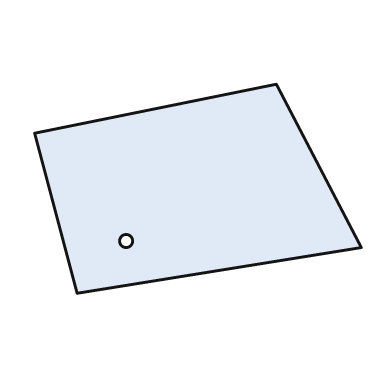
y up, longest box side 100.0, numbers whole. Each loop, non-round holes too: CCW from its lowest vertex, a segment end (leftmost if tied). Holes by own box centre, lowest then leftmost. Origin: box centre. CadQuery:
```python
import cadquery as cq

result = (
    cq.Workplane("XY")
    .moveTo(-37.0, -32.0)
    .lineTo(50.0, -18.0)
    .lineTo(24.0, 32.0)
    .lineTo(-50.0, 17.0)
    .close()
    .moveTo(-22.0, -16.0)
    .circle(2.0)
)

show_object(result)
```